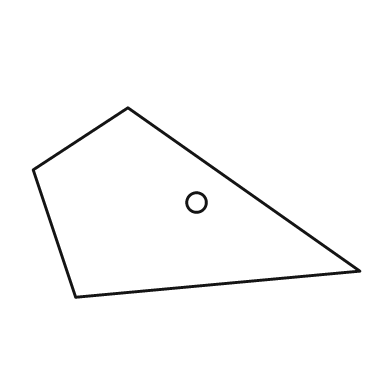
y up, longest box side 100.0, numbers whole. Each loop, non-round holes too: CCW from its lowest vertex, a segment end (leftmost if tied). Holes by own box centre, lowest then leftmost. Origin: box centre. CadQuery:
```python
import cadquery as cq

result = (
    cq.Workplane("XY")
    .moveTo(-37.0, -29.0)
    .lineTo(50.0, -21.0)
    .lineTo(-21.0, 29.0)
    .lineTo(-50.0, 10.0)
    .close()
    .moveTo(0.0, 0.0)
    .circle(3.0)
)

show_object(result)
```